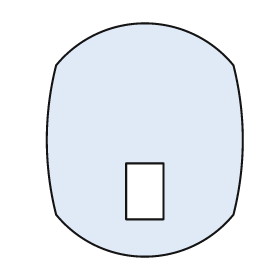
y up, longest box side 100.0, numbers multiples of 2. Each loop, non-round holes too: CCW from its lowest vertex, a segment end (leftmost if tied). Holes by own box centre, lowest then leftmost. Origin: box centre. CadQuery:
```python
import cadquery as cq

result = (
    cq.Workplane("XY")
    .moveTo(-38.0, -32.0)
    .threePointArc((0.0, -50.0), (38.0, -32.0))
    .threePointArc((42.0, 0.0), (38.0, 32.0))
    .threePointArc((0.0, 50.0), (-38.0, 32.0))
    .threePointArc((-42.0, 0.0), (-38.0, -32.0))
    .close()
    .moveTo(-8.0, -34.0)
    .lineTo(8.0, -34.0)
    .lineTo(8.0, -10.0)
    .lineTo(-8.0, -10.0)
    .close()
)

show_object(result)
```